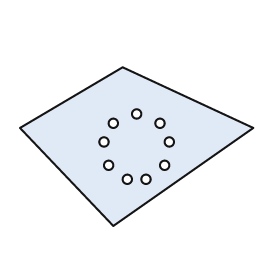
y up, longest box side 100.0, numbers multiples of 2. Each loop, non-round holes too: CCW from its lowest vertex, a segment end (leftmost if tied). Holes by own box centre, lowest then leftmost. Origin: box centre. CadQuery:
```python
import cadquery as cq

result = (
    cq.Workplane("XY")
    .moveTo(-10.0, -34.0)
    .lineTo(50.0, 8.0)
    .lineTo(-6.0, 34.0)
    .lineTo(-50.0, 8.0)
    .close()
    .moveTo(-4.0, -14.0)
    .circle(2.0)
    .moveTo(4.0, -14.0)
    .circle(2.0)
    .moveTo(-12.0, -8.0)
    .circle(2.0)
    .moveTo(12.0, -8.0)
    .circle(2.0)
    .moveTo(-14.0, 2.0)
    .circle(2.0)
    .moveTo(14.0, 2.0)
    .circle(2.0)
    .moveTo(-10.0, 10.0)
    .circle(2.0)
    .moveTo(10.0, 10.0)
    .circle(2.0)
    .moveTo(0.0, 14.0)
    .circle(2.0)
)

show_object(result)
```